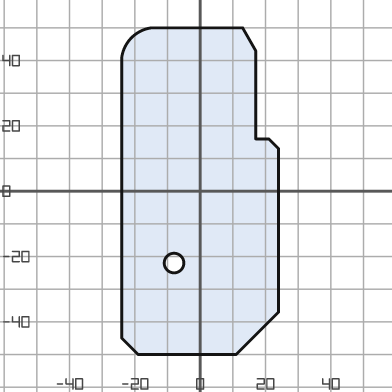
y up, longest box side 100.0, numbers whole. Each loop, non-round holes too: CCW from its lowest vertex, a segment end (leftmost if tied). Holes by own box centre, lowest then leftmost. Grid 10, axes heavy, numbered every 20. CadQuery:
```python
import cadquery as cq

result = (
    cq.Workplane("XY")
    .moveTo(-19.0, -50.0)
    .lineTo(11.0, -50.0)
    .lineTo(24.0, -37.0)
    .lineTo(24.0, 13.0)
    .lineTo(21.0, 16.0)
    .lineTo(17.0, 16.0)
    .lineTo(17.0, 43.0)
    .lineTo(13.0, 50.0)
    .lineTo(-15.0, 50.0)
    .threePointArc((-21.0, 47.0), (-24.0, 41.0))
    .lineTo(-24.0, -45.0)
    .close()
    .moveTo(-8.0, -22.0)
    .circle(3.0)
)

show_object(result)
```